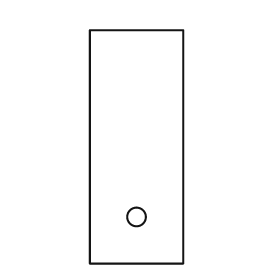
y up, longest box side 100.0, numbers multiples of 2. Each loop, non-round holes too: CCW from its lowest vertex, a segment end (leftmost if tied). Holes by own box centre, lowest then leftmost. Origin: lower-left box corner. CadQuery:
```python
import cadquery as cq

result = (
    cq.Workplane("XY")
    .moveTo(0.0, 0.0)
    .lineTo(40.0, 0.0)
    .lineTo(40.0, 100.0)
    .lineTo(0.0, 100.0)
    .close()
    .moveTo(20.0, 20.0)
    .circle(4.0)
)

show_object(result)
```